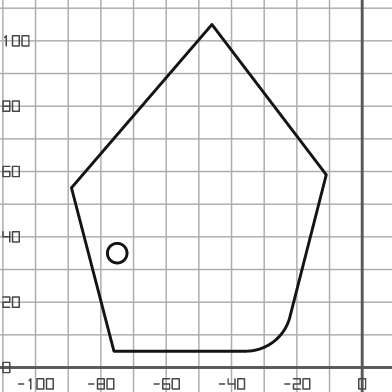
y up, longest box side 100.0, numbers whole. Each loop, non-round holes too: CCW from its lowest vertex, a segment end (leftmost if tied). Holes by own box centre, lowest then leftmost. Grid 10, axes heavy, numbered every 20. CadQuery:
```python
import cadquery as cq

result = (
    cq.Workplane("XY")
    .moveTo(-76.0, 5.0)
    .lineTo(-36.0, 5.0)
    .threePointArc((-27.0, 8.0), (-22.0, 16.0))
    .lineTo(-11.0, 59.0)
    .lineTo(-46.0, 105.0)
    .lineTo(-89.0, 55.0)
    .close()
    .moveTo(-75.0, 35.0)
    .circle(3.0)
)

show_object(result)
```